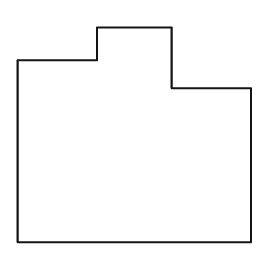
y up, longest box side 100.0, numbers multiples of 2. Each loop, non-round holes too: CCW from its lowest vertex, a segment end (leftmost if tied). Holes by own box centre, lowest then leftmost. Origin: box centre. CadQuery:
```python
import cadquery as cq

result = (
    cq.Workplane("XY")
    .moveTo(-50.0, -46.0)
    .lineTo(50.0, -46.0)
    .lineTo(50.0, 20.0)
    .lineTo(16.0, 20.0)
    .lineTo(16.0, 46.0)
    .lineTo(-16.0, 46.0)
    .lineTo(-16.0, 32.0)
    .lineTo(-50.0, 32.0)
    .close()
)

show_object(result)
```